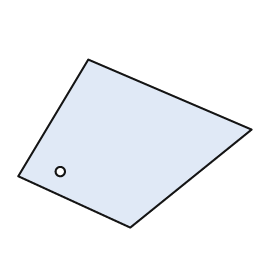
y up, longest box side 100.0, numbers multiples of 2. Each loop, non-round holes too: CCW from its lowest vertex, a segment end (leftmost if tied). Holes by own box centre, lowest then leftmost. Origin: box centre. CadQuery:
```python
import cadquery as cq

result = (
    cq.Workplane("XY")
    .moveTo(-2.0, -36.0)
    .lineTo(50.0, 6.0)
    .lineTo(-20.0, 36.0)
    .lineTo(-50.0, -14.0)
    .close()
    .moveTo(-32.0, -12.0)
    .circle(2.0)
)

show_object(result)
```